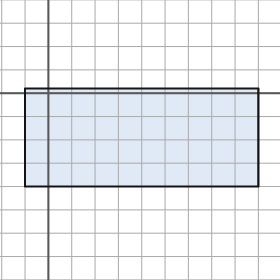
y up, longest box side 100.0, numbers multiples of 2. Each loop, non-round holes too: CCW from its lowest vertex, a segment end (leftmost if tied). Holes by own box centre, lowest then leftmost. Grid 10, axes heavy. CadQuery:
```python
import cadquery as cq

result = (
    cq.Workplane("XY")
    .moveTo(-10.0, -40.0)
    .lineTo(90.0, -40.0)
    .lineTo(90.0, 2.0)
    .lineTo(-10.0, 2.0)
    .close()
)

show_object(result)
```